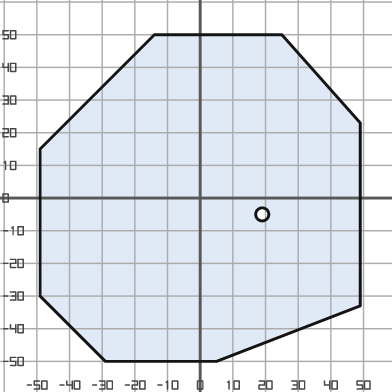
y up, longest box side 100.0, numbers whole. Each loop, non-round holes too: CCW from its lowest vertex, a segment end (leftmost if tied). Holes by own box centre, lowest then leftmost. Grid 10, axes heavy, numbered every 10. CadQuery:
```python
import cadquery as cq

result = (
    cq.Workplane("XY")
    .moveTo(-29.0, -50.0)
    .lineTo(5.0, -50.0)
    .lineTo(49.0, -33.0)
    .lineTo(49.0, 23.0)
    .lineTo(25.0, 50.0)
    .lineTo(-14.0, 50.0)
    .lineTo(-49.0, 15.0)
    .lineTo(-49.0, -30.0)
    .close()
    .moveTo(19.0, -5.0)
    .circle(2.0)
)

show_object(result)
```